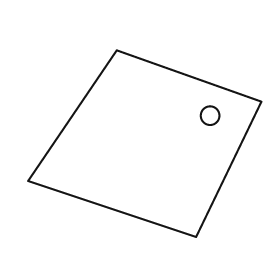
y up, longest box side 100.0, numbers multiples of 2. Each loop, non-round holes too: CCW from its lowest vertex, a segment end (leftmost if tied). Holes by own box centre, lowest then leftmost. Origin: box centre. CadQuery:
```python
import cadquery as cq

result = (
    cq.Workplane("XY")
    .moveTo(22.0, -40.0)
    .lineTo(50.0, 18.0)
    .lineTo(-12.0, 40.0)
    .lineTo(-50.0, -16.0)
    .close()
    .moveTo(28.0, 12.0)
    .circle(4.0)
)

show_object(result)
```